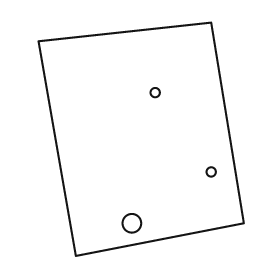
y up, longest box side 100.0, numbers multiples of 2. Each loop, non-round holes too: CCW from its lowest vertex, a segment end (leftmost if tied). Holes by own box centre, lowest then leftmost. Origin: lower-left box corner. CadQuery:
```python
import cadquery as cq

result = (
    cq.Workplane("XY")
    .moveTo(16.0, 0.0)
    .lineTo(88.0, 14.0)
    .lineTo(74.0, 100.0)
    .lineTo(0.0, 92.0)
    .close()
    .moveTo(40.0, 14.0)
    .circle(4.0)
    .moveTo(74.0, 36.0)
    .circle(2.0)
    .moveTo(50.0, 70.0)
    .circle(2.0)
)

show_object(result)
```